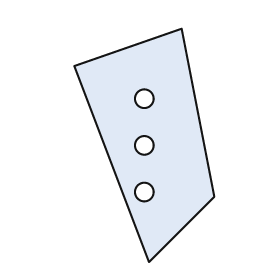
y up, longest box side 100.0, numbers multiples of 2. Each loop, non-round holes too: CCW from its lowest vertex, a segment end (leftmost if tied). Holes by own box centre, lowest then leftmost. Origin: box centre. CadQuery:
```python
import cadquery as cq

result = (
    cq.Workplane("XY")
    .moveTo(2.0, -50.0)
    .lineTo(30.0, -22.0)
    .lineTo(16.0, 50.0)
    .lineTo(-30.0, 34.0)
    .close()
    .moveTo(0.0, -20.0)
    .circle(4.0)
    .moveTo(0.0, 0.0)
    .circle(4.0)
    .moveTo(0.0, 20.0)
    .circle(4.0)
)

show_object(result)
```